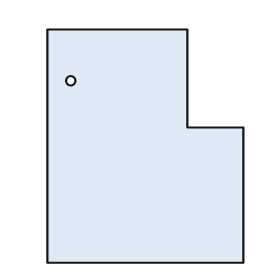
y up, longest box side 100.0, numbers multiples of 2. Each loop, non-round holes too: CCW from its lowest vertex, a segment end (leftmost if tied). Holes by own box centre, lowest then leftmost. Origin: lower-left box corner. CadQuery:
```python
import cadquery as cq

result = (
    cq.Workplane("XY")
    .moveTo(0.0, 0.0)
    .lineTo(84.0, 0.0)
    .lineTo(84.0, 58.0)
    .lineTo(60.0, 58.0)
    .lineTo(60.0, 100.0)
    .lineTo(0.0, 100.0)
    .close()
    .moveTo(10.0, 78.0)
    .circle(2.0)
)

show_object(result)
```